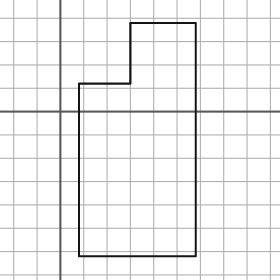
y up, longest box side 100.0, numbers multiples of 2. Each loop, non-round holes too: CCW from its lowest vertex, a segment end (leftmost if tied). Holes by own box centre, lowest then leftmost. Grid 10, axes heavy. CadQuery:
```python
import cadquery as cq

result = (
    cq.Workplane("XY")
    .moveTo(8.0, -62.0)
    .lineTo(58.0, -62.0)
    .lineTo(58.0, 38.0)
    .lineTo(30.0, 38.0)
    .lineTo(30.0, 12.0)
    .lineTo(8.0, 12.0)
    .close()
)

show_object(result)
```